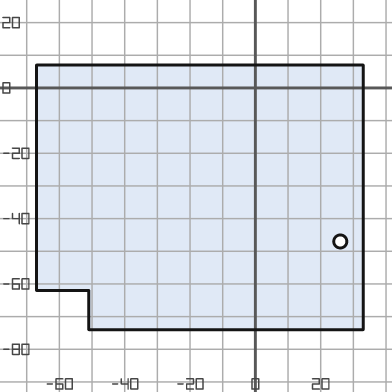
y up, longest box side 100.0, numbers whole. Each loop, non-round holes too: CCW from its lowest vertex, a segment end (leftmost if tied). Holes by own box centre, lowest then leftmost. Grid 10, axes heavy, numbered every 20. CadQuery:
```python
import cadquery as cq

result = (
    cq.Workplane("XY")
    .moveTo(-51.0, -74.0)
    .lineTo(33.0, -74.0)
    .lineTo(33.0, 7.0)
    .lineTo(-67.0, 7.0)
    .lineTo(-67.0, -62.0)
    .lineTo(-51.0, -62.0)
    .close()
    .moveTo(26.0, -47.0)
    .circle(2.0)
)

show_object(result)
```